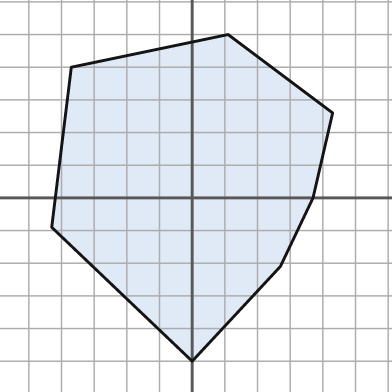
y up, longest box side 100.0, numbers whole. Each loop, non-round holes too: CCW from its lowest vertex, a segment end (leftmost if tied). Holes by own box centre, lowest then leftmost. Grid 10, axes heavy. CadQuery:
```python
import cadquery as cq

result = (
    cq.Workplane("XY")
    .moveTo(0.0, -50.0)
    .lineTo(27.0, -21.0)
    .lineTo(37.0, 0.0)
    .lineTo(43.0, 26.0)
    .lineTo(11.0, 50.0)
    .lineTo(-37.0, 40.0)
    .lineTo(-43.0, -9.0)
    .close()
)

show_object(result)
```